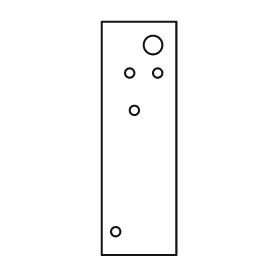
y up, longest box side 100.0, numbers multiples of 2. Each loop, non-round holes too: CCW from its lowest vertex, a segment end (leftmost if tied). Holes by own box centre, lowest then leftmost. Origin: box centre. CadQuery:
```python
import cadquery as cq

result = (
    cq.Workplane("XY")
    .moveTo(-16.0, -50.0)
    .lineTo(16.0, -50.0)
    .lineTo(16.0, 50.0)
    .lineTo(-16.0, 50.0)
    .close()
    .moveTo(-10.0, -40.0)
    .circle(2.0)
    .moveTo(-2.0, 12.0)
    .circle(2.0)
    .moveTo(-4.0, 28.0)
    .circle(2.0)
    .moveTo(8.0, 28.0)
    .circle(2.0)
    .moveTo(6.0, 40.0)
    .circle(4.0)
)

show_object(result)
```